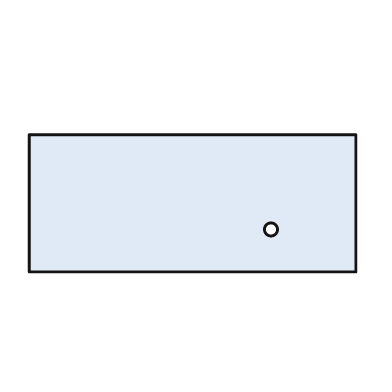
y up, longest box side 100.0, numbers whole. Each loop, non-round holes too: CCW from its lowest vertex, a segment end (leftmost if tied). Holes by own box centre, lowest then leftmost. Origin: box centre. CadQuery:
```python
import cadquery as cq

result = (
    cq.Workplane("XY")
    .moveTo(-50.0, -21.0)
    .lineTo(50.0, -21.0)
    .lineTo(50.0, 21.0)
    .lineTo(-50.0, 21.0)
    .close()
    .moveTo(24.0, -8.0)
    .circle(2.0)
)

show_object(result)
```